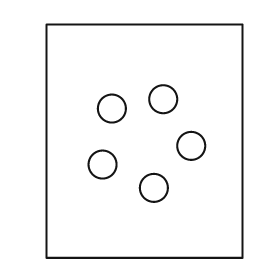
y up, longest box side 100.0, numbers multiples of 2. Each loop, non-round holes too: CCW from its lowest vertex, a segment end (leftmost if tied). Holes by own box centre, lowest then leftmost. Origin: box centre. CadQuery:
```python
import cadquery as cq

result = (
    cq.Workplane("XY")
    .moveTo(-42.0, -50.0)
    .lineTo(42.0, -50.0)
    .lineTo(42.0, 50.0)
    .lineTo(-42.0, 50.0)
    .close()
    .moveTo(4.0, -20.0)
    .circle(6.0)
    .moveTo(-18.0, -10.0)
    .circle(6.0)
    .moveTo(20.0, -2.0)
    .circle(6.0)
    .moveTo(-14.0, 14.0)
    .circle(6.0)
    .moveTo(8.0, 18.0)
    .circle(6.0)
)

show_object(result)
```